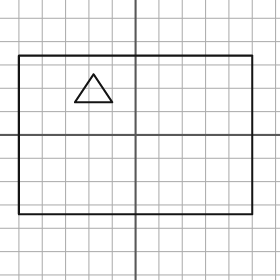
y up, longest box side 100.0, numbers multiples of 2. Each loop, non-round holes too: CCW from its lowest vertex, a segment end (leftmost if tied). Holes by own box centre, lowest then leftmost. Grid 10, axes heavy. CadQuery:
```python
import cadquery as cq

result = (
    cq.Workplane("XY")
    .moveTo(-50.0, -34.0)
    .lineTo(50.0, -34.0)
    .lineTo(50.0, 34.0)
    .lineTo(-50.0, 34.0)
    .close()
    .moveTo(-26.0, 14.0)
    .lineTo(-10.0, 14.0)
    .lineTo(-18.0, 26.0)
    .close()
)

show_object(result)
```